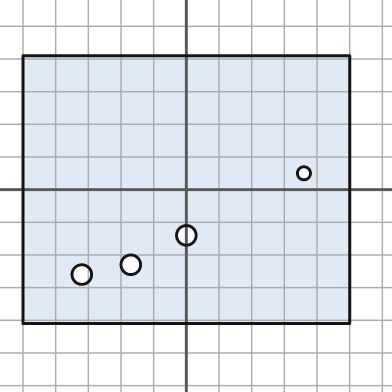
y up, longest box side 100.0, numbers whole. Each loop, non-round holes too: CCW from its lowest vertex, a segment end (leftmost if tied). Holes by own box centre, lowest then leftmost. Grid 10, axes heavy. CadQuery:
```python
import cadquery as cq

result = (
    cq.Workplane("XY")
    .moveTo(-50.0, -41.0)
    .lineTo(50.0, -41.0)
    .lineTo(50.0, 41.0)
    .lineTo(-50.0, 41.0)
    .close()
    .moveTo(-32.0, -26.0)
    .circle(3.0)
    .moveTo(-17.0, -23.0)
    .circle(3.0)
    .moveTo(0.0, -14.0)
    .circle(3.0)
    .moveTo(36.0, 5.0)
    .circle(2.0)
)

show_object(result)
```